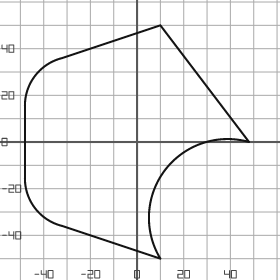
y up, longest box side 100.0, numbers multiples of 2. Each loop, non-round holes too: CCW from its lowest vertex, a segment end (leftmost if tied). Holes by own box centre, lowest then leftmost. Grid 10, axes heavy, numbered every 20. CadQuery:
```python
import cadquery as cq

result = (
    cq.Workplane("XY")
    .moveTo(10.0, -50.0)
    .threePointArc((12.0, -12.0), (48.0, 0.0))
    .lineTo(10.0, 50.0)
    .lineTo(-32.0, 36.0)
    .threePointArc((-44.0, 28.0), (-48.0, 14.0))
    .lineTo(-48.0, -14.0)
    .threePointArc((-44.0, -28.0), (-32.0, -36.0))
    .close()
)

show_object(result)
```